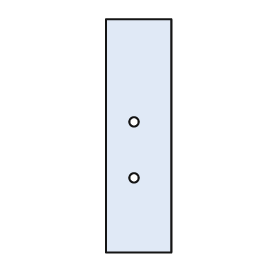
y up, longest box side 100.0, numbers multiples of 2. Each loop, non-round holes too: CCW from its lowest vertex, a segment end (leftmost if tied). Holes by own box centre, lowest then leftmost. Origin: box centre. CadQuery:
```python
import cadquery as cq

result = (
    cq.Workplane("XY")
    .moveTo(-14.0, -50.0)
    .lineTo(14.0, -50.0)
    .lineTo(14.0, 50.0)
    .lineTo(-14.0, 50.0)
    .close()
    .moveTo(-2.0, -18.0)
    .circle(2.0)
    .moveTo(-2.0, 6.0)
    .circle(2.0)
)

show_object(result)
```